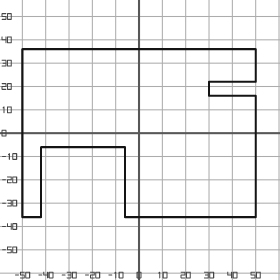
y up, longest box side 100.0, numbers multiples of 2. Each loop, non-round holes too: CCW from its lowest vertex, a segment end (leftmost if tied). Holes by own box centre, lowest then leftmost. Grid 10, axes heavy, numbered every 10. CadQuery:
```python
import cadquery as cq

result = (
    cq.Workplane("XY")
    .moveTo(-50.0, -36.0)
    .lineTo(-42.0, -36.0)
    .lineTo(-42.0, -6.0)
    .lineTo(-6.0, -6.0)
    .lineTo(-6.0, -36.0)
    .lineTo(50.0, -36.0)
    .lineTo(50.0, 16.0)
    .lineTo(30.0, 16.0)
    .lineTo(30.0, 22.0)
    .lineTo(50.0, 22.0)
    .lineTo(50.0, 36.0)
    .lineTo(-50.0, 36.0)
    .close()
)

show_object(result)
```